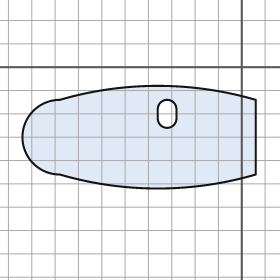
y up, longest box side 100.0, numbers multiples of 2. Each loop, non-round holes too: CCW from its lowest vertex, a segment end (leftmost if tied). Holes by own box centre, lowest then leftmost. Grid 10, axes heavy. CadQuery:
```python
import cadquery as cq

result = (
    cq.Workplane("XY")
    .moveTo(-78.0, -46.0)
    .threePointArc((-36.0, -52.0), (6.0, -46.0))
    .lineTo(6.0, -14.0)
    .threePointArc((-36.0, -8.0), (-78.0, -14.0))
    .threePointArc((-94.0, -30.0), (-78.0, -46.0))
    .close()
    .moveTo(-36.0, -22.0)
    .threePointArc((-32.0, -26.0), (-28.0, -22.0))
    .lineTo(-28.0, -18.0)
    .threePointArc((-32.0, -14.0), (-36.0, -18.0))
    .close()
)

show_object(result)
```